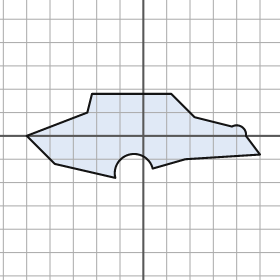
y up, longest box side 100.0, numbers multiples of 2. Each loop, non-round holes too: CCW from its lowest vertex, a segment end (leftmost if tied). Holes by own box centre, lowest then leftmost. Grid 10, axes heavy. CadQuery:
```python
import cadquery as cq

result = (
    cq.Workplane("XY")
    .moveTo(-12.0, -18.0)
    .threePointArc((-6.0, -8.0), (4.0, -14.0))
    .lineTo(18.0, -10.0)
    .lineTo(50.0, -8.0)
    .lineTo(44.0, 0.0)
    .threePointArc((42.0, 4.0), (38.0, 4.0))
    .lineTo(22.0, 8.0)
    .lineTo(12.0, 18.0)
    .lineTo(-22.0, 18.0)
    .lineTo(-24.0, 10.0)
    .lineTo(-50.0, 0.0)
    .lineTo(-38.0, -12.0)
    .close()
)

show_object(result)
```